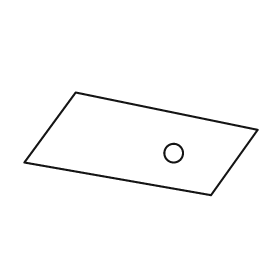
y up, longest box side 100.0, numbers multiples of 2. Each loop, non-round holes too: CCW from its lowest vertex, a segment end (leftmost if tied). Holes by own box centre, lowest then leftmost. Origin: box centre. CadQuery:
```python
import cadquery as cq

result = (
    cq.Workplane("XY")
    .moveTo(30.0, -22.0)
    .lineTo(50.0, 6.0)
    .lineTo(-28.0, 22.0)
    .lineTo(-50.0, -8.0)
    .close()
    .moveTo(14.0, -4.0)
    .circle(4.0)
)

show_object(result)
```